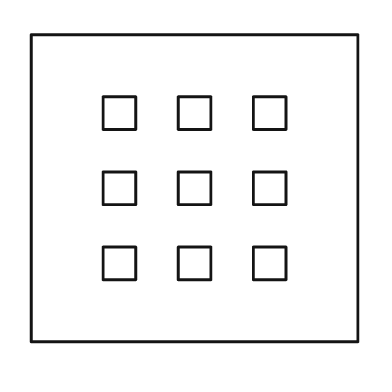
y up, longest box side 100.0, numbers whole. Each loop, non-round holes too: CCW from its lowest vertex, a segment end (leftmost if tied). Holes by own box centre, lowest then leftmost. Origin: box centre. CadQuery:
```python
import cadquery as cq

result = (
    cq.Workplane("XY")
    .moveTo(-50.0, -47.0)
    .lineTo(50.0, -47.0)
    .lineTo(50.0, 47.0)
    .lineTo(-50.0, 47.0)
    .close()
    .moveTo(-28.0, -28.0)
    .lineTo(-18.0, -28.0)
    .lineTo(-18.0, -18.0)
    .lineTo(-28.0, -18.0)
    .close()
    .moveTo(-5.0, -28.0)
    .lineTo(5.0, -28.0)
    .lineTo(5.0, -18.0)
    .lineTo(-5.0, -18.0)
    .close()
    .moveTo(18.0, -28.0)
    .lineTo(28.0, -28.0)
    .lineTo(28.0, -18.0)
    .lineTo(18.0, -18.0)
    .close()
    .moveTo(-28.0, -5.0)
    .lineTo(-18.0, -5.0)
    .lineTo(-18.0, 5.0)
    .lineTo(-28.0, 5.0)
    .close()
    .moveTo(-5.0, -5.0)
    .lineTo(5.0, -5.0)
    .lineTo(5.0, 5.0)
    .lineTo(-5.0, 5.0)
    .close()
    .moveTo(18.0, -5.0)
    .lineTo(28.0, -5.0)
    .lineTo(28.0, 5.0)
    .lineTo(18.0, 5.0)
    .close()
    .moveTo(-28.0, 18.0)
    .lineTo(-18.0, 18.0)
    .lineTo(-18.0, 28.0)
    .lineTo(-28.0, 28.0)
    .close()
    .moveTo(-5.0, 18.0)
    .lineTo(5.0, 18.0)
    .lineTo(5.0, 28.0)
    .lineTo(-5.0, 28.0)
    .close()
    .moveTo(18.0, 18.0)
    .lineTo(28.0, 18.0)
    .lineTo(28.0, 28.0)
    .lineTo(18.0, 28.0)
    .close()
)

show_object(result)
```